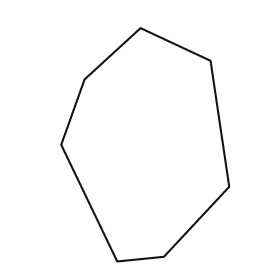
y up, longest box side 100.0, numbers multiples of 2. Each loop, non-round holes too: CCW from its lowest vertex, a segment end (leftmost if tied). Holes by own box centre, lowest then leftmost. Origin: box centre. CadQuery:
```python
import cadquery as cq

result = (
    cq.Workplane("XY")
    .moveTo(-12.0, -50.0)
    .lineTo(8.0, -48.0)
    .lineTo(36.0, -18.0)
    .lineTo(28.0, 36.0)
    .lineTo(-2.0, 50.0)
    .lineTo(-26.0, 28.0)
    .lineTo(-36.0, 0.0)
    .close()
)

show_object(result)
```